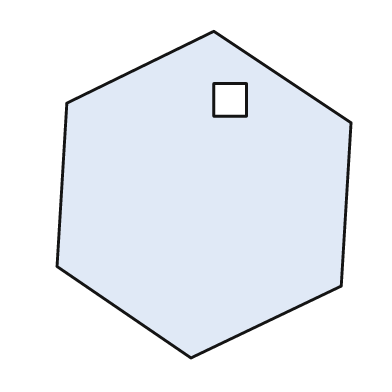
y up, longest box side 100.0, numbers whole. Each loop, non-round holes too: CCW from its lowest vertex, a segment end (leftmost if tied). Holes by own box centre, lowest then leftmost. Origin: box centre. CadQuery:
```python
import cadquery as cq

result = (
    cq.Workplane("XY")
    .moveTo(-4.0, -50.0)
    .lineTo(42.0, -28.0)
    .lineTo(45.0, 22.0)
    .lineTo(3.0, 50.0)
    .lineTo(-42.0, 28.0)
    .lineTo(-45.0, -22.0)
    .close()
    .moveTo(3.0, 24.0)
    .lineTo(13.0, 24.0)
    .lineTo(13.0, 34.0)
    .lineTo(3.0, 34.0)
    .close()
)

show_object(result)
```